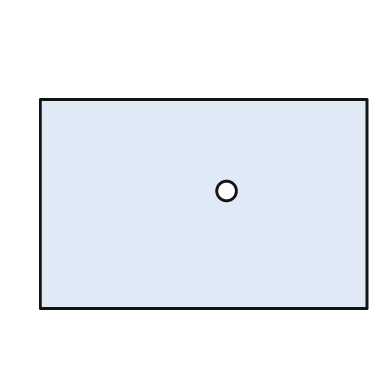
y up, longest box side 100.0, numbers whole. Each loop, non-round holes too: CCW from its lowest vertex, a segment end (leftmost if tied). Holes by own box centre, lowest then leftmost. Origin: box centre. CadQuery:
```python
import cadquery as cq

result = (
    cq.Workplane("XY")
    .moveTo(-50.0, -32.0)
    .lineTo(50.0, -32.0)
    .lineTo(50.0, 32.0)
    .lineTo(-50.0, 32.0)
    .close()
    .moveTo(7.0, 4.0)
    .circle(3.0)
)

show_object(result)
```